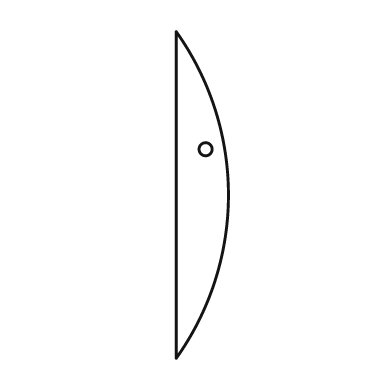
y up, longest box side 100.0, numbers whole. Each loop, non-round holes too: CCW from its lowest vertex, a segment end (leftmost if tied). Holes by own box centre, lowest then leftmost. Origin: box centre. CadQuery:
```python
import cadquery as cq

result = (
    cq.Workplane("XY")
    .moveTo(-8.0, -50.0)
    .threePointArc((8.0, 0.0), (-8.0, 50.0))
    .close()
    .moveTo(1.0, 14.0)
    .circle(2.0)
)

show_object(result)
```